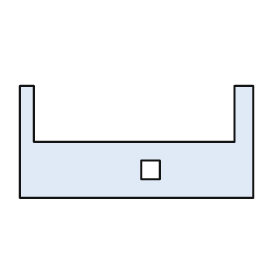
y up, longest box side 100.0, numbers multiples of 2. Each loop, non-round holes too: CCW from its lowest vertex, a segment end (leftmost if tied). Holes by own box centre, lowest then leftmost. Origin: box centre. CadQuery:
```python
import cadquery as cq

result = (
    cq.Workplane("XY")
    .moveTo(-50.0, -24.0)
    .lineTo(50.0, -24.0)
    .lineTo(50.0, 24.0)
    .lineTo(42.0, 24.0)
    .lineTo(42.0, 0.0)
    .lineTo(-44.0, 0.0)
    .lineTo(-44.0, 24.0)
    .lineTo(-50.0, 24.0)
    .close()
    .moveTo(2.0, -16.0)
    .lineTo(10.0, -16.0)
    .lineTo(10.0, -8.0)
    .lineTo(2.0, -8.0)
    .close()
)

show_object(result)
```